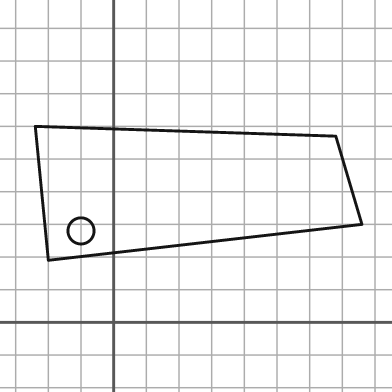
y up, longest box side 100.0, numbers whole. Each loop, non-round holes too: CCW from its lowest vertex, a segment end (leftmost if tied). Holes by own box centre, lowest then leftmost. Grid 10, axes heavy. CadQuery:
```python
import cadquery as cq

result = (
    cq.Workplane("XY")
    .moveTo(-20.0, 19.0)
    .lineTo(76.0, 30.0)
    .lineTo(68.0, 57.0)
    .lineTo(-24.0, 60.0)
    .close()
    .moveTo(-10.0, 28.0)
    .circle(4.0)
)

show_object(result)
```